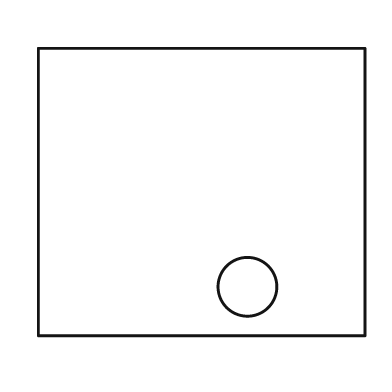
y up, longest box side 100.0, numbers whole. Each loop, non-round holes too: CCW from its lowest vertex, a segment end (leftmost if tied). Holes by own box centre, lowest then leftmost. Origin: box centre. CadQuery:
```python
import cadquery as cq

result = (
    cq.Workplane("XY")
    .moveTo(-50.0, -44.0)
    .lineTo(50.0, -44.0)
    .lineTo(50.0, 44.0)
    .lineTo(-50.0, 44.0)
    .close()
    .moveTo(14.0, -29.0)
    .circle(9.0)
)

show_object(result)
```